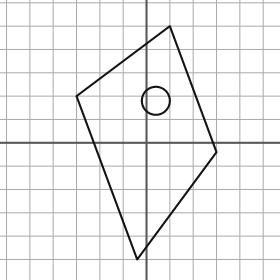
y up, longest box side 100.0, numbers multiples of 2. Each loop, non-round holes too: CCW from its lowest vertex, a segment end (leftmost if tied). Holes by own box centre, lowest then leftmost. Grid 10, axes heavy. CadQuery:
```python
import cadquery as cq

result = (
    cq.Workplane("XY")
    .moveTo(-4.0, -50.0)
    .lineTo(30.0, -4.0)
    .lineTo(10.0, 50.0)
    .lineTo(-30.0, 20.0)
    .close()
    .moveTo(4.0, 18.0)
    .circle(6.0)
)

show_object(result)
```